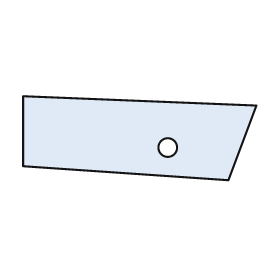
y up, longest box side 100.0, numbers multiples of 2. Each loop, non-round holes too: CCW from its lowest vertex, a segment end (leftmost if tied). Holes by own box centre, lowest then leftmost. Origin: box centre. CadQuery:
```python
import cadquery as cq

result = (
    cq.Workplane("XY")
    .moveTo(38.0, -18.0)
    .lineTo(50.0, 14.0)
    .lineTo(-50.0, 18.0)
    .lineTo(-50.0, -12.0)
    .close()
    .moveTo(12.0, -4.0)
    .circle(4.0)
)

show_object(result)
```